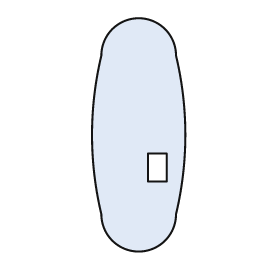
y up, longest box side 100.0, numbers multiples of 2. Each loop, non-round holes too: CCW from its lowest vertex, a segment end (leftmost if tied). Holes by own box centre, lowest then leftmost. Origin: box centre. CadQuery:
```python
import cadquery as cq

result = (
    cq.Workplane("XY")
    .moveTo(-16.0, -34.0)
    .threePointArc((0.0, -50.0), (16.0, -34.0))
    .threePointArc((20.0, 0.0), (16.0, 34.0))
    .threePointArc((0.0, 50.0), (-16.0, 34.0))
    .threePointArc((-20.0, 0.0), (-16.0, -34.0))
    .close()
    .moveTo(4.0, -20.0)
    .lineTo(12.0, -20.0)
    .lineTo(12.0, -8.0)
    .lineTo(4.0, -8.0)
    .close()
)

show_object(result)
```